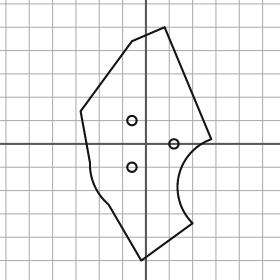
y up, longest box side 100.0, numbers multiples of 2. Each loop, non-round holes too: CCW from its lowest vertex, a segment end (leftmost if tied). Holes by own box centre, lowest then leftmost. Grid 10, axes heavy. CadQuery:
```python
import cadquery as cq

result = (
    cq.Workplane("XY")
    .moveTo(-2.0, -50.0)
    .lineTo(20.0, -34.0)
    .threePointArc((14.0, -14.0), (28.0, 2.0))
    .lineTo(8.0, 50.0)
    .lineTo(-6.0, 44.0)
    .lineTo(-28.0, 14.0)
    .lineTo(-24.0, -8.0)
    .threePointArc((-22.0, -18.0), (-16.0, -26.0))
    .close()
    .moveTo(-6.0, -10.0)
    .circle(2.0)
    .moveTo(12.0, 0.0)
    .circle(2.0)
    .moveTo(-6.0, 10.0)
    .circle(2.0)
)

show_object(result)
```